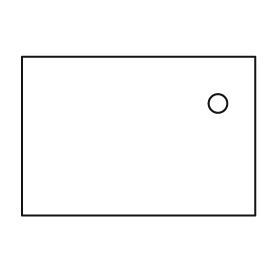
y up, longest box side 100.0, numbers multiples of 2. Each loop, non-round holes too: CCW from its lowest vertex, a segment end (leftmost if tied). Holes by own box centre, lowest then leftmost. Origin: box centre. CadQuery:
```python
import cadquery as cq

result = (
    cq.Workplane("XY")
    .moveTo(-50.0, -34.0)
    .lineTo(50.0, -34.0)
    .lineTo(50.0, 34.0)
    .lineTo(-50.0, 34.0)
    .close()
    .moveTo(34.0, 14.0)
    .circle(4.0)
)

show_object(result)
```